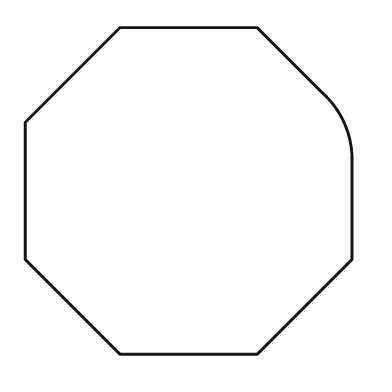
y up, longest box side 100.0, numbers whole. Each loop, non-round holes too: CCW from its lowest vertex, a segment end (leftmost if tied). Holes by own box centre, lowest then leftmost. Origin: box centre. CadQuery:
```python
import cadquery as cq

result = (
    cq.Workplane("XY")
    .moveTo(-21.0, -50.0)
    .lineTo(21.0, -50.0)
    .lineTo(50.0, -21.0)
    .lineTo(50.0, 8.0)
    .threePointArc((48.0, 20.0), (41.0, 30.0))
    .lineTo(21.0, 50.0)
    .lineTo(-21.0, 50.0)
    .lineTo(-50.0, 21.0)
    .lineTo(-50.0, -21.0)
    .close()
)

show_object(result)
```